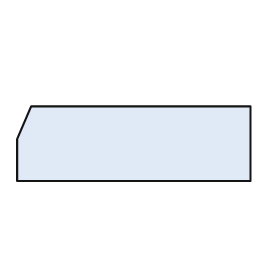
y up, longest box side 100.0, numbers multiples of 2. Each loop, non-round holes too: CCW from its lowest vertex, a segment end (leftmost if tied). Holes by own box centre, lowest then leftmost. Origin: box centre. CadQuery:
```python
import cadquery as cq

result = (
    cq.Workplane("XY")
    .moveTo(-50.0, -16.0)
    .lineTo(50.0, -16.0)
    .lineTo(50.0, 16.0)
    .lineTo(-44.0, 16.0)
    .lineTo(-50.0, 2.0)
    .close()
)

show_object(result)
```